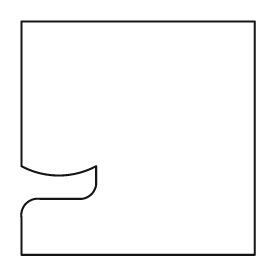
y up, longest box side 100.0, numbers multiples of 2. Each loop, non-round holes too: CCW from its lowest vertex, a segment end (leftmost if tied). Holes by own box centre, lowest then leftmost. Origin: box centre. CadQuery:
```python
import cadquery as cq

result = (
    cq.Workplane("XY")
    .moveTo(-50.0, -50.0)
    .lineTo(50.0, -50.0)
    .lineTo(50.0, 50.0)
    .lineTo(-50.0, 50.0)
    .lineTo(-50.0, -12.0)
    .threePointArc((-34.0, -16.0), (-18.0, -12.0))
    .lineTo(-18.0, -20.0)
    .threePointArc((-20.0, -24.0), (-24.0, -26.0))
    .lineTo(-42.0, -26.0)
    .threePointArc((-48.0, -28.0), (-50.0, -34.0))
    .close()
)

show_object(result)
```